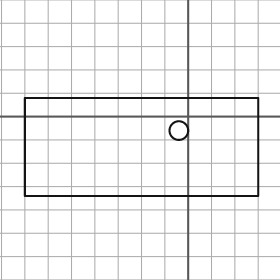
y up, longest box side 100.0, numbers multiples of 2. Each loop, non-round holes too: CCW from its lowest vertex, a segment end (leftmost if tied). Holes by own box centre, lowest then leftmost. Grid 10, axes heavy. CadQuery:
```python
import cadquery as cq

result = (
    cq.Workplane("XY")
    .moveTo(-70.0, -34.0)
    .lineTo(30.0, -34.0)
    .lineTo(30.0, 8.0)
    .lineTo(-70.0, 8.0)
    .close()
    .moveTo(-4.0, -6.0)
    .circle(4.0)
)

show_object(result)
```